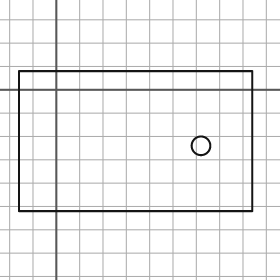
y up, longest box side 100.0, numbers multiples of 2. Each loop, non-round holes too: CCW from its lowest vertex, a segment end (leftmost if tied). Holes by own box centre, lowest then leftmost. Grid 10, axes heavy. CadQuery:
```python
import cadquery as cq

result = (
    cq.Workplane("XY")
    .moveTo(-16.0, -52.0)
    .lineTo(84.0, -52.0)
    .lineTo(84.0, 8.0)
    .lineTo(-16.0, 8.0)
    .close()
    .moveTo(62.0, -24.0)
    .circle(4.0)
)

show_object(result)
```